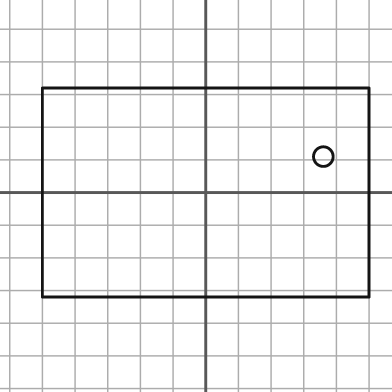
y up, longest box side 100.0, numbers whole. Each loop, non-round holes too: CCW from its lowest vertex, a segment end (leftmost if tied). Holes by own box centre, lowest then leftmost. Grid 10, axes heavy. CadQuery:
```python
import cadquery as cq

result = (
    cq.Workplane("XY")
    .moveTo(-50.0, -32.0)
    .lineTo(50.0, -32.0)
    .lineTo(50.0, 32.0)
    .lineTo(-50.0, 32.0)
    .close()
    .moveTo(36.0, 11.0)
    .circle(3.0)
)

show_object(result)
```